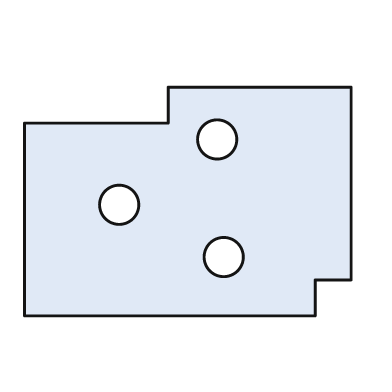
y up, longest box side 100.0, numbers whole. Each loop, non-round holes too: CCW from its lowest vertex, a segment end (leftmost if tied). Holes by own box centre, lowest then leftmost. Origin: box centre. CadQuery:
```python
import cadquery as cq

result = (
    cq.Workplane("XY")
    .moveTo(-50.0, -35.0)
    .lineTo(39.0, -35.0)
    .lineTo(39.0, -24.0)
    .lineTo(50.0, -24.0)
    .lineTo(50.0, 35.0)
    .lineTo(-6.0, 35.0)
    .lineTo(-6.0, 24.0)
    .lineTo(-50.0, 24.0)
    .close()
    .moveTo(11.0, -17.0)
    .circle(6.0)
    .moveTo(-21.0, -1.0)
    .circle(6.0)
    .moveTo(9.0, 19.0)
    .circle(6.0)
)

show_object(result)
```